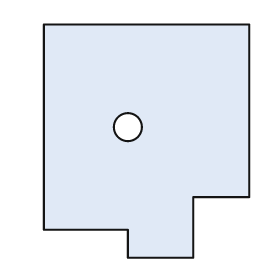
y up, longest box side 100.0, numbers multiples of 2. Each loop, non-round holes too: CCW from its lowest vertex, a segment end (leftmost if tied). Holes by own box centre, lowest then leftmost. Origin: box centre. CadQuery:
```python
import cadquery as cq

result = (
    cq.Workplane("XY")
    .moveTo(-8.0, -50.0)
    .lineTo(20.0, -50.0)
    .lineTo(20.0, -24.0)
    .lineTo(44.0, -24.0)
    .lineTo(44.0, 50.0)
    .lineTo(-44.0, 50.0)
    .lineTo(-44.0, -38.0)
    .lineTo(-8.0, -38.0)
    .close()
    .moveTo(-8.0, 6.0)
    .circle(6.0)
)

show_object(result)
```